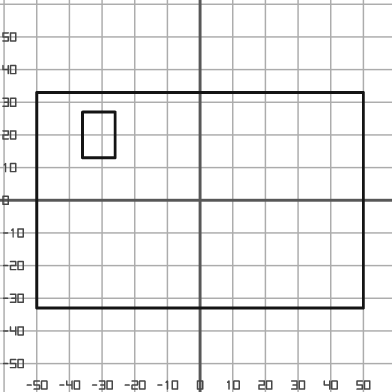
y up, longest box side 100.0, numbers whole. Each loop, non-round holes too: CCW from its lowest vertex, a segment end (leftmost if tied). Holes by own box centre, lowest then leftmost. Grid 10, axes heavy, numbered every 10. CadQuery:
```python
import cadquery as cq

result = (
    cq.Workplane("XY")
    .moveTo(-50.0, -33.0)
    .lineTo(50.0, -33.0)
    .lineTo(50.0, 33.0)
    .lineTo(-50.0, 33.0)
    .close()
    .moveTo(-36.0, 13.0)
    .lineTo(-26.0, 13.0)
    .lineTo(-26.0, 27.0)
    .lineTo(-36.0, 27.0)
    .close()
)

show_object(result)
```